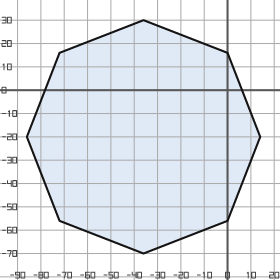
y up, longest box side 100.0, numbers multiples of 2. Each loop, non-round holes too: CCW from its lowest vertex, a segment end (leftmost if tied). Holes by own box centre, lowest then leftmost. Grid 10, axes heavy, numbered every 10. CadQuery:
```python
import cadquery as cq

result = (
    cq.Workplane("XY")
    .moveTo(-36.0, -70.0)
    .lineTo(0.0, -56.0)
    .lineTo(14.0, -20.0)
    .lineTo(0.0, 16.0)
    .lineTo(-36.0, 30.0)
    .lineTo(-72.0, 16.0)
    .lineTo(-86.0, -20.0)
    .lineTo(-72.0, -56.0)
    .close()
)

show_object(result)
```